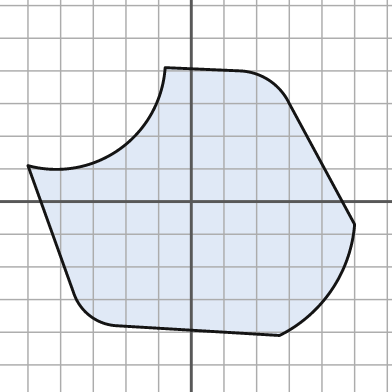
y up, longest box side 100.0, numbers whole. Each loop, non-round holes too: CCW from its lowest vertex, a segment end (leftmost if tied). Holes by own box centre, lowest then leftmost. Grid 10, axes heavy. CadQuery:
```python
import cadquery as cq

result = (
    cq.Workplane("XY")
    .moveTo(27.0, -41.0)
    .threePointArc((43.0, -27.0), (50.0, -7.0))
    .lineTo(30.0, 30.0)
    .threePointArc((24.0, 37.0), (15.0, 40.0))
    .lineTo(-8.0, 41.0)
    .threePointArc((-22.0, 16.0), (-50.0, 11.0))
    .lineTo(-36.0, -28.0)
    .threePointArc((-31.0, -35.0), (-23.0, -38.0))
    .close()
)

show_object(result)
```